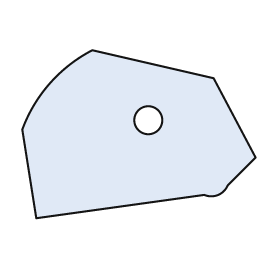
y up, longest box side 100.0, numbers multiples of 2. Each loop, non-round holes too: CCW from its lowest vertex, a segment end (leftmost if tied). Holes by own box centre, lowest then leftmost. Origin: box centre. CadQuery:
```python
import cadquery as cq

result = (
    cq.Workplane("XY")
    .moveTo(-44.0, -36.0)
    .lineTo(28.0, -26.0)
    .threePointArc((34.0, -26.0), (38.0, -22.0))
    .lineTo(50.0, -10.0)
    .lineTo(32.0, 24.0)
    .lineTo(-20.0, 36.0)
    .threePointArc((-38.0, 22.0), (-50.0, 2.0))
    .close()
    .moveTo(4.0, 6.0)
    .circle(6.0)
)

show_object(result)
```